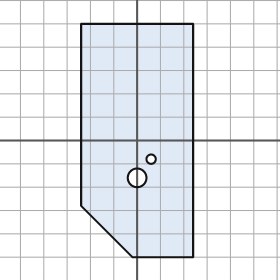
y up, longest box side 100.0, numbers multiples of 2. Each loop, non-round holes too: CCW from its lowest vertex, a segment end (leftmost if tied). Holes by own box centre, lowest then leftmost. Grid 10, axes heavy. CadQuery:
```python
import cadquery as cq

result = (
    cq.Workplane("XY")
    .moveTo(-2.0, -50.0)
    .lineTo(24.0, -50.0)
    .lineTo(24.0, 50.0)
    .lineTo(-24.0, 50.0)
    .lineTo(-24.0, -28.0)
    .close()
    .moveTo(0.0, -16.0)
    .circle(4.0)
    .moveTo(6.0, -8.0)
    .circle(2.0)
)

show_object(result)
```